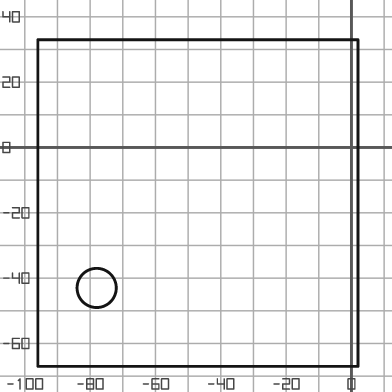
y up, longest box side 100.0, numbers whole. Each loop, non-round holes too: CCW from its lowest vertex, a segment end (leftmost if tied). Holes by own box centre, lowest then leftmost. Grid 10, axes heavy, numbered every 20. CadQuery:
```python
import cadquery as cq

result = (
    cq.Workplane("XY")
    .moveTo(-96.0, -67.0)
    .lineTo(2.0, -67.0)
    .lineTo(2.0, 33.0)
    .lineTo(-96.0, 33.0)
    .close()
    .moveTo(-78.0, -43.0)
    .circle(6.0)
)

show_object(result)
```